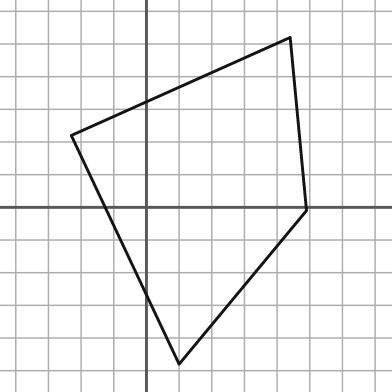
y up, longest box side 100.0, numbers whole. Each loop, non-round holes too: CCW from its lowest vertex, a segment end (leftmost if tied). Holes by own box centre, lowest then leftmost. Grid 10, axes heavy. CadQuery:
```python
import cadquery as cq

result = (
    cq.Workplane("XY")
    .moveTo(10.0, -48.0)
    .lineTo(49.0, -1.0)
    .lineTo(44.0, 52.0)
    .lineTo(-23.0, 22.0)
    .close()
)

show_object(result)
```